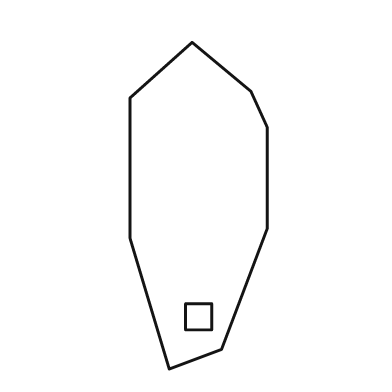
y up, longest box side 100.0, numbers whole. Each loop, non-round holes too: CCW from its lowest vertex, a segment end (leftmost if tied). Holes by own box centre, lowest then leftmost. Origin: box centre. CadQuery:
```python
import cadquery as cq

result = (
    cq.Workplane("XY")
    .moveTo(-9.0, -50.0)
    .lineTo(7.0, -44.0)
    .lineTo(21.0, -7.0)
    .lineTo(21.0, 24.0)
    .lineTo(16.0, 35.0)
    .lineTo(-2.0, 50.0)
    .lineTo(-21.0, 33.0)
    .lineTo(-21.0, -10.0)
    .close()
    .moveTo(-4.0, -38.0)
    .lineTo(4.0, -38.0)
    .lineTo(4.0, -30.0)
    .lineTo(-4.0, -30.0)
    .close()
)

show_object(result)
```